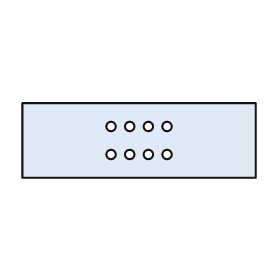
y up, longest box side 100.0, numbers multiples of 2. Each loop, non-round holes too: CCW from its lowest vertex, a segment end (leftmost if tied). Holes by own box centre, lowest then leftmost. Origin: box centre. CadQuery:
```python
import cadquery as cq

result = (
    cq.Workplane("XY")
    .moveTo(-50.0, -16.0)
    .lineTo(50.0, -16.0)
    .lineTo(50.0, 16.0)
    .lineTo(-50.0, 16.0)
    .close()
    .moveTo(-12.0, -6.0)
    .circle(2.0)
    .moveTo(-4.0, -6.0)
    .circle(2.0)
    .moveTo(4.0, -6.0)
    .circle(2.0)
    .moveTo(12.0, -6.0)
    .circle(2.0)
    .moveTo(-12.0, 6.0)
    .circle(2.0)
    .moveTo(-4.0, 6.0)
    .circle(2.0)
    .moveTo(4.0, 6.0)
    .circle(2.0)
    .moveTo(12.0, 6.0)
    .circle(2.0)
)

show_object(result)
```